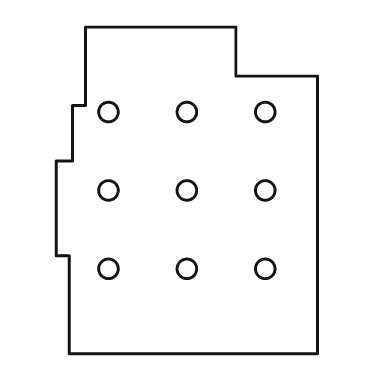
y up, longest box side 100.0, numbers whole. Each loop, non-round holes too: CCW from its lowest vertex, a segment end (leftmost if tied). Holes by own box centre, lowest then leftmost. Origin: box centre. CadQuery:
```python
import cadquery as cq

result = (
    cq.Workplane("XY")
    .moveTo(-36.0, -50.0)
    .lineTo(40.0, -50.0)
    .lineTo(40.0, 35.0)
    .lineTo(15.0, 35.0)
    .lineTo(15.0, 50.0)
    .lineTo(-31.0, 50.0)
    .lineTo(-31.0, 26.0)
    .lineTo(-35.0, 26.0)
    .lineTo(-35.0, 9.0)
    .lineTo(-40.0, 9.0)
    .lineTo(-40.0, -20.0)
    .lineTo(-36.0, -20.0)
    .close()
    .moveTo(-24.0, -24.0)
    .circle(3.0)
    .moveTo(0.0, -24.0)
    .circle(3.0)
    .moveTo(24.0, -24.0)
    .circle(3.0)
    .moveTo(-24.0, 0.0)
    .circle(3.0)
    .moveTo(0.0, 0.0)
    .circle(3.0)
    .moveTo(24.0, 0.0)
    .circle(3.0)
    .moveTo(-24.0, 24.0)
    .circle(3.0)
    .moveTo(0.0, 24.0)
    .circle(3.0)
    .moveTo(24.0, 24.0)
    .circle(3.0)
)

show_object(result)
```